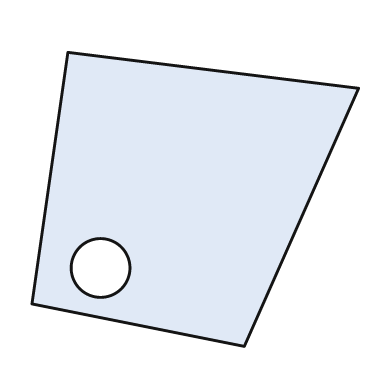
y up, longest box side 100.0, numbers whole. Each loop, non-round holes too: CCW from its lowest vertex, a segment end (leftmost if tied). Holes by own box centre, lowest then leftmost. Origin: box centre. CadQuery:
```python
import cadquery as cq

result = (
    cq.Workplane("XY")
    .moveTo(15.0, -45.0)
    .lineTo(50.0, 34.0)
    .lineTo(-39.0, 45.0)
    .lineTo(-50.0, -32.0)
    .close()
    .moveTo(-29.0, -21.0)
    .circle(9.0)
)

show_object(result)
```